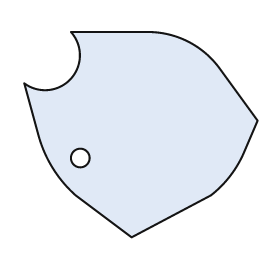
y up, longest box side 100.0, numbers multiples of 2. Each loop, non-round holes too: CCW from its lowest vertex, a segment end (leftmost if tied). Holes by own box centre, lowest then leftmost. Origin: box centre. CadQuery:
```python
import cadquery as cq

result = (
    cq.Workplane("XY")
    .moveTo(-4.0, -44.0)
    .lineTo(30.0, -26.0)
    .threePointArc((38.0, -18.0), (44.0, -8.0))
    .lineTo(50.0, 6.0)
    .lineTo(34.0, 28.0)
    .threePointArc((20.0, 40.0), (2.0, 44.0))
    .lineTo(-30.0, 44.0)
    .threePointArc((-30.0, 24.0), (-50.0, 22.0))
    .lineTo(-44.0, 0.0)
    .threePointArc((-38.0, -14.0), (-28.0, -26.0))
    .close()
    .moveTo(-26.0, -10.0)
    .circle(4.0)
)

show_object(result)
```